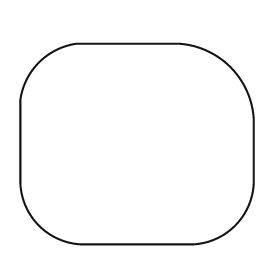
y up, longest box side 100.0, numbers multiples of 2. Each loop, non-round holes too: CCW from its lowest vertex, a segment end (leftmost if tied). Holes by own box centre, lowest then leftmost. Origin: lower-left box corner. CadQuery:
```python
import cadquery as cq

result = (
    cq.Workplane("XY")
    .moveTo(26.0, 0.0)
    .lineTo(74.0, 0.0)
    .threePointArc((92.0, 8.0), (100.0, 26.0))
    .lineTo(100.0, 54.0)
    .threePointArc((90.0, 76.0), (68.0, 86.0))
    .lineTo(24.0, 86.0)
    .threePointArc((8.0, 78.0), (0.0, 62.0))
    .lineTo(0.0, 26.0)
    .threePointArc((8.0, 8.0), (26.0, 0.0))
    .close()
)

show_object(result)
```